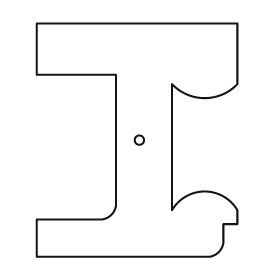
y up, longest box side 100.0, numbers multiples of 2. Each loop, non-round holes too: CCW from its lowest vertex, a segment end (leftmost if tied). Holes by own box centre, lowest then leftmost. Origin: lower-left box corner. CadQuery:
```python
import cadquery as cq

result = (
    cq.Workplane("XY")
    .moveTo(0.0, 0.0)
    .lineTo(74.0, 0.0)
    .threePointArc((78.0, 2.0), (80.0, 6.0))
    .lineTo(80.0, 14.0)
    .lineTo(86.0, 14.0)
    .lineTo(86.0, 20.0)
    .threePointArc((72.0, 28.0), (58.0, 20.0))
    .lineTo(58.0, 74.0)
    .threePointArc((72.0, 68.0), (86.0, 74.0))
    .lineTo(86.0, 100.0)
    .lineTo(0.0, 100.0)
    .lineTo(0.0, 78.0)
    .lineTo(34.0, 78.0)
    .lineTo(34.0, 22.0)
    .threePointArc((32.0, 18.0), (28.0, 16.0))
    .lineTo(0.0, 16.0)
    .close()
    .moveTo(44.0, 50.0)
    .circle(2.0)
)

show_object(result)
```